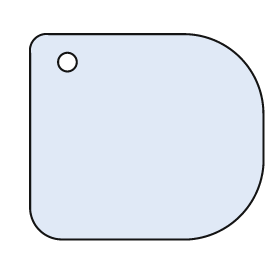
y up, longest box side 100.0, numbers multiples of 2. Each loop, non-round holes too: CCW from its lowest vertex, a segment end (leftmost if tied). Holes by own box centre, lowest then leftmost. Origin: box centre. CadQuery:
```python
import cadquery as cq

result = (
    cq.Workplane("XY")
    .moveTo(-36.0, -44.0)
    .lineTo(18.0, -44.0)
    .threePointArc((40.0, -34.0), (50.0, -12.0))
    .lineTo(50.0, 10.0)
    .threePointArc((40.0, 34.0), (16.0, 44.0))
    .lineTo(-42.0, 44.0)
    .threePointArc((-48.0, 42.0), (-50.0, 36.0))
    .lineTo(-50.0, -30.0)
    .threePointArc((-46.0, -40.0), (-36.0, -44.0))
    .close()
    .moveTo(-34.0, 32.0)
    .circle(4.0)
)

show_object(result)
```